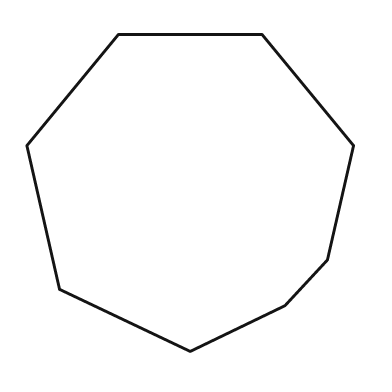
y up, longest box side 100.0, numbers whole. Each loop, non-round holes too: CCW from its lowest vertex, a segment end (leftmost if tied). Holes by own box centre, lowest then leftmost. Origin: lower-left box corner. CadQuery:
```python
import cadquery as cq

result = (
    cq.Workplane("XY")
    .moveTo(50.0, 0.0)
    .lineTo(79.0, 14.0)
    .lineTo(92.0, 28.0)
    .lineTo(100.0, 63.0)
    .lineTo(72.0, 97.0)
    .lineTo(28.0, 97.0)
    .lineTo(0.0, 63.0)
    .lineTo(10.0, 19.0)
    .close()
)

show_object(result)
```